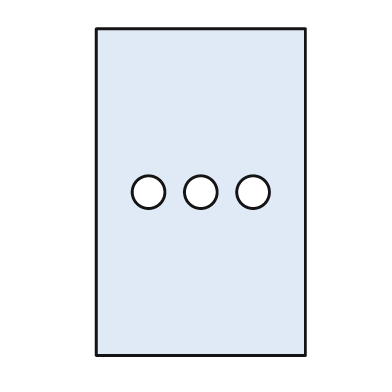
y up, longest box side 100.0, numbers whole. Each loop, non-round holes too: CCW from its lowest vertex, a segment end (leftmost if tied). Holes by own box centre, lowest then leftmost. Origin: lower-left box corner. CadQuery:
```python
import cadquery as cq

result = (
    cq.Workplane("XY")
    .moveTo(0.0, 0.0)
    .lineTo(64.0, 0.0)
    .lineTo(64.0, 100.0)
    .lineTo(0.0, 100.0)
    .close()
    .moveTo(16.0, 50.0)
    .circle(5.0)
    .moveTo(32.0, 50.0)
    .circle(5.0)
    .moveTo(48.0, 50.0)
    .circle(5.0)
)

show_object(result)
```